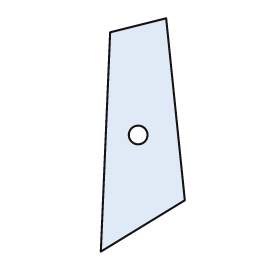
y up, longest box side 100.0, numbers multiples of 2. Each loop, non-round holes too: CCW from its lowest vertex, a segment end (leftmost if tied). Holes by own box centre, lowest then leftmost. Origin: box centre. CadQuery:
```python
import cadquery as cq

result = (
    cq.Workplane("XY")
    .moveTo(-18.0, -50.0)
    .lineTo(18.0, -28.0)
    .lineTo(10.0, 50.0)
    .lineTo(-14.0, 44.0)
    .close()
    .moveTo(-2.0, 0.0)
    .circle(4.0)
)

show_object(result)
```